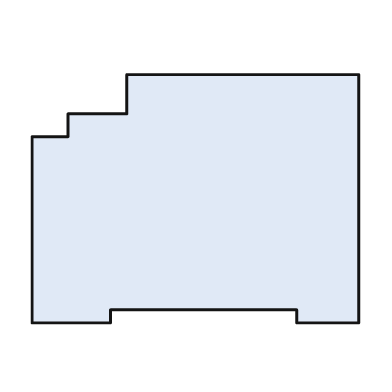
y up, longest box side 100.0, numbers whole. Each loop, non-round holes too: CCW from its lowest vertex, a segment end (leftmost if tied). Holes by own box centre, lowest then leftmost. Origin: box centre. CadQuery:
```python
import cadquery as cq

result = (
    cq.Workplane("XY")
    .moveTo(-50.0, -38.0)
    .lineTo(-26.0, -38.0)
    .lineTo(-26.0, -34.0)
    .lineTo(31.0, -34.0)
    .lineTo(31.0, -38.0)
    .lineTo(50.0, -38.0)
    .lineTo(50.0, 38.0)
    .lineTo(-21.0, 38.0)
    .lineTo(-21.0, 26.0)
    .lineTo(-39.0, 26.0)
    .lineTo(-39.0, 19.0)
    .lineTo(-50.0, 19.0)
    .close()
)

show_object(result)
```